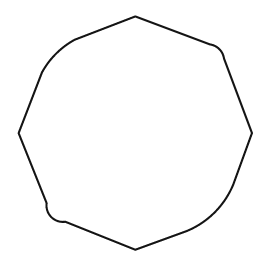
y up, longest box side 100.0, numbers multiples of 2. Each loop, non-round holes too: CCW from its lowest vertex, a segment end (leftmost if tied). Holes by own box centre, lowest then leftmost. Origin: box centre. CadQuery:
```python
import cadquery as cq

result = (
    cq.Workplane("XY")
    .moveTo(0.0, -50.0)
    .lineTo(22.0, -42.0)
    .threePointArc((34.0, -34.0), (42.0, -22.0))
    .lineTo(50.0, 0.0)
    .lineTo(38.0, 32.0)
    .threePointArc((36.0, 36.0), (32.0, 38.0))
    .lineTo(0.0, 50.0)
    .lineTo(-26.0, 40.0)
    .threePointArc((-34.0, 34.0), (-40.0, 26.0))
    .lineTo(-50.0, 0.0)
    .lineTo(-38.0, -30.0)
    .threePointArc((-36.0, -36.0), (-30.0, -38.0))
    .close()
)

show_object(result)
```